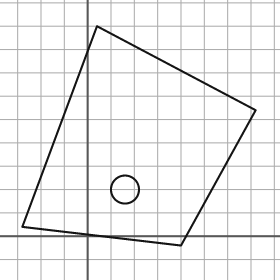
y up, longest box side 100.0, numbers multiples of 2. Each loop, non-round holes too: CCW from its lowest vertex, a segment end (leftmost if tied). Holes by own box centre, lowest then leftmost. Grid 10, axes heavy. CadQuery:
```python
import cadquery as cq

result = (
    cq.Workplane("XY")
    .moveTo(40.0, -4.0)
    .lineTo(72.0, 54.0)
    .lineTo(4.0, 90.0)
    .lineTo(-28.0, 4.0)
    .close()
    .moveTo(16.0, 20.0)
    .circle(6.0)
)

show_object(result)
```